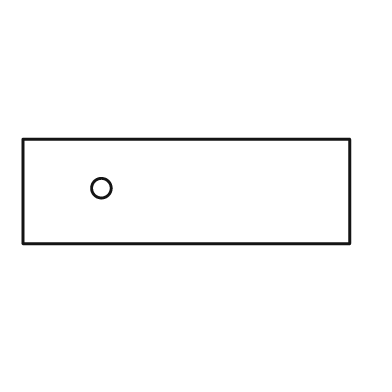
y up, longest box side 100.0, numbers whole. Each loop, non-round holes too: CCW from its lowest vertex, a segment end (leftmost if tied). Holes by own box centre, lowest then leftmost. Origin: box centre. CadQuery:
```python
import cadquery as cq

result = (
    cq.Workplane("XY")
    .moveTo(-50.0, -16.0)
    .lineTo(50.0, -16.0)
    .lineTo(50.0, 16.0)
    .lineTo(-50.0, 16.0)
    .close()
    .moveTo(-26.0, 1.0)
    .circle(3.0)
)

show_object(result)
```